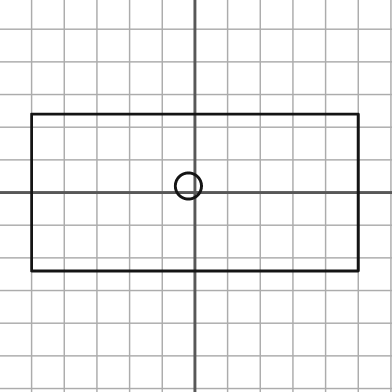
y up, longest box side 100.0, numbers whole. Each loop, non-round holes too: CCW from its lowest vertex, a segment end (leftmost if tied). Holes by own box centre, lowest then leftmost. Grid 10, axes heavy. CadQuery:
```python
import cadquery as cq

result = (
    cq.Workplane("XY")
    .moveTo(-50.0, -24.0)
    .lineTo(50.0, -24.0)
    .lineTo(50.0, 24.0)
    .lineTo(-50.0, 24.0)
    .close()
    .moveTo(-2.0, 2.0)
    .circle(4.0)
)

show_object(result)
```